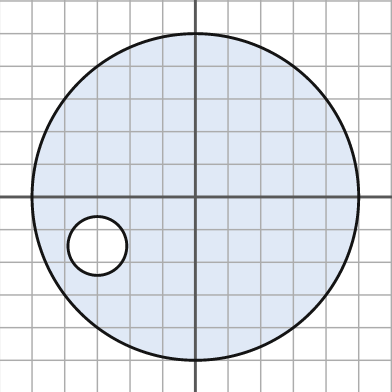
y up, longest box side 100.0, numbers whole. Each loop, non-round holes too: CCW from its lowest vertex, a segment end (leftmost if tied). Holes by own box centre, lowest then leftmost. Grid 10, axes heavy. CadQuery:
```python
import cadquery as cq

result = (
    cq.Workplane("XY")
    .moveTo(0.0, 0.0)
    .circle(50.0)
    .moveTo(-30.0, -15.0)
    .circle(9.0)
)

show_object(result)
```